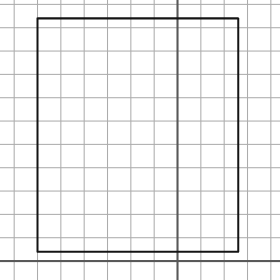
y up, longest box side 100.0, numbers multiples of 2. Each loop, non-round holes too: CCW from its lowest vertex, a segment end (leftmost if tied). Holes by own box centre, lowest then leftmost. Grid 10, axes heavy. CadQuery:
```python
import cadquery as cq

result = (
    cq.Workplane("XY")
    .moveTo(-60.0, 4.0)
    .lineTo(26.0, 4.0)
    .lineTo(26.0, 104.0)
    .lineTo(-60.0, 104.0)
    .close()
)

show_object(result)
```